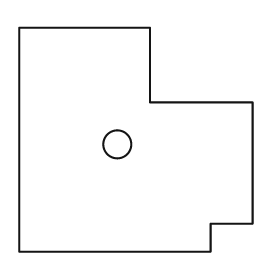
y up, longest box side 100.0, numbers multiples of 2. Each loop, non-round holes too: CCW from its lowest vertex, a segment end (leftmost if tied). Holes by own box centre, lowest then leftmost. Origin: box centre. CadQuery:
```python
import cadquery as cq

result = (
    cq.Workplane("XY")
    .moveTo(-50.0, -48.0)
    .lineTo(32.0, -48.0)
    .lineTo(32.0, -36.0)
    .lineTo(50.0, -36.0)
    .lineTo(50.0, 16.0)
    .lineTo(6.0, 16.0)
    .lineTo(6.0, 48.0)
    .lineTo(-50.0, 48.0)
    .close()
    .moveTo(-8.0, -2.0)
    .circle(6.0)
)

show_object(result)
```